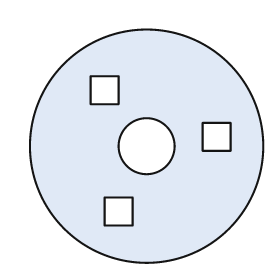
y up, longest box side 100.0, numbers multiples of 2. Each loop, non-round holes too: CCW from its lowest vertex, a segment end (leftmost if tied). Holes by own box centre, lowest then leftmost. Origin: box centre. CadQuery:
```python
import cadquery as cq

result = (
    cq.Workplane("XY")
    .moveTo(0.0, 0.0)
    .circle(50.0)
    .moveTo(-18.0, -34.0)
    .lineTo(-6.0, -34.0)
    .lineTo(-6.0, -22.0)
    .lineTo(-18.0, -22.0)
    .close()
    .moveTo(0.0, 0.0)
    .circle(12.0)
    .moveTo(24.0, -2.0)
    .lineTo(36.0, -2.0)
    .lineTo(36.0, 10.0)
    .lineTo(24.0, 10.0)
    .close()
    .moveTo(-24.0, 18.0)
    .lineTo(-12.0, 18.0)
    .lineTo(-12.0, 30.0)
    .lineTo(-24.0, 30.0)
    .close()
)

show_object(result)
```